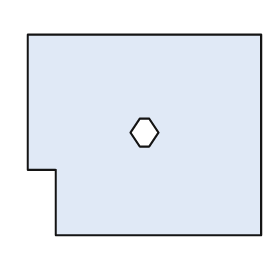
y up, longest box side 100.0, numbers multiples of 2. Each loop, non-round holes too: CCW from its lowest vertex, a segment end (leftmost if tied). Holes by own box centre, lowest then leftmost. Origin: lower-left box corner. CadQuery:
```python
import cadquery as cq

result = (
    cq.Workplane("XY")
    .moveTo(12.0, 0.0)
    .lineTo(100.0, 0.0)
    .lineTo(100.0, 86.0)
    .lineTo(0.0, 86.0)
    .lineTo(0.0, 28.0)
    .lineTo(12.0, 28.0)
    .close()
    .moveTo(48.0, 38.0)
    .lineTo(52.0, 38.0)
    .lineTo(56.0, 44.0)
    .lineTo(52.0, 50.0)
    .lineTo(48.0, 50.0)
    .lineTo(44.0, 44.0)
    .close()
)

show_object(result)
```